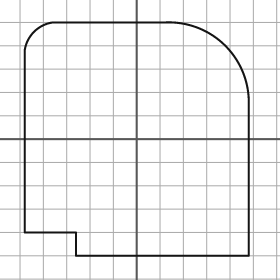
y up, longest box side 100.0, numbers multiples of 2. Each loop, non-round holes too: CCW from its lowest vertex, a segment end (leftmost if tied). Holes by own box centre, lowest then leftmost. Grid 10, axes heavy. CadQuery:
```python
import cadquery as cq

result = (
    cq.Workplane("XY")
    .moveTo(-26.0, -50.0)
    .lineTo(48.0, -50.0)
    .lineTo(48.0, 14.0)
    .threePointArc((38.0, 40.0), (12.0, 50.0))
    .lineTo(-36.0, 50.0)
    .threePointArc((-44.0, 46.0), (-48.0, 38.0))
    .lineTo(-48.0, -40.0)
    .lineTo(-26.0, -40.0)
    .close()
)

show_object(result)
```